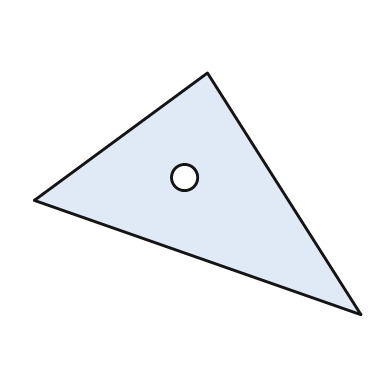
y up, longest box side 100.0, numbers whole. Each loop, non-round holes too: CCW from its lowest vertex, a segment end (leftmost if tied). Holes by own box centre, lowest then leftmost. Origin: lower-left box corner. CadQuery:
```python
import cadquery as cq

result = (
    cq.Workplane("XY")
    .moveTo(100.0, 0.0)
    .lineTo(53.0, 74.0)
    .lineTo(0.0, 35.0)
    .close()
    .moveTo(46.0, 42.0)
    .circle(4.0)
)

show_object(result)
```